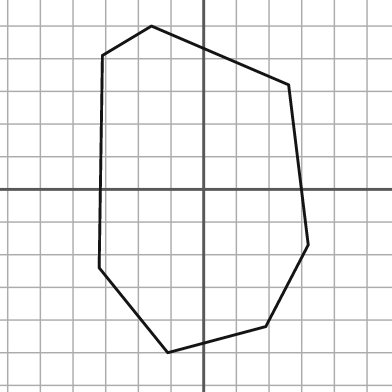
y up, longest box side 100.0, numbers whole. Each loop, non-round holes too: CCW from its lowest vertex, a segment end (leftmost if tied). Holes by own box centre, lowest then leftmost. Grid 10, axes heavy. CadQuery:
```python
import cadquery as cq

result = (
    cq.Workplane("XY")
    .moveTo(-11.0, -50.0)
    .lineTo(19.0, -42.0)
    .lineTo(32.0, -17.0)
    .lineTo(26.0, 32.0)
    .lineTo(-16.0, 50.0)
    .lineTo(-31.0, 41.0)
    .lineTo(-32.0, -24.0)
    .close()
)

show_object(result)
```